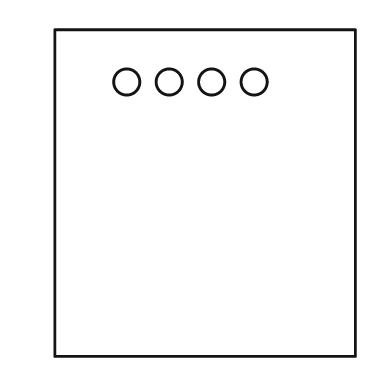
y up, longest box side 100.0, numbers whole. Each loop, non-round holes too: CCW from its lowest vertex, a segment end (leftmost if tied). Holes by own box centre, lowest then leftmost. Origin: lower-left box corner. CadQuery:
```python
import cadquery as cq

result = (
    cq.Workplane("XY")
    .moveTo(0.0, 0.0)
    .lineTo(92.0, 0.0)
    .lineTo(92.0, 100.0)
    .lineTo(0.0, 100.0)
    .close()
    .moveTo(22.0, 84.0)
    .circle(4.0)
    .moveTo(35.0, 84.0)
    .circle(4.0)
    .moveTo(48.0, 84.0)
    .circle(4.0)
    .moveTo(61.0, 84.0)
    .circle(4.0)
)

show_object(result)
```